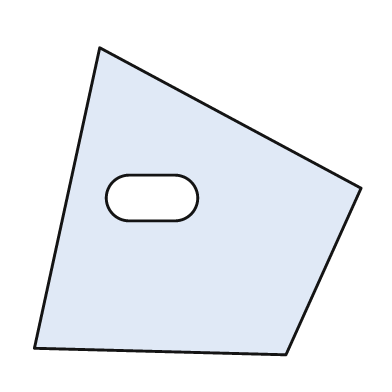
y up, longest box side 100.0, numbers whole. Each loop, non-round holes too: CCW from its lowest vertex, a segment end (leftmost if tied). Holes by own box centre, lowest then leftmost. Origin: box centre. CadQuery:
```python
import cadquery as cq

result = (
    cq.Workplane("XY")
    .moveTo(27.0, -47.0)
    .lineTo(50.0, 4.0)
    .lineTo(-30.0, 47.0)
    .lineTo(-50.0, -45.0)
    .close()
    .moveTo(-21.0, -6.0)
    .lineTo(-7.0, -6.0)
    .threePointArc((0.0, 1.0), (-7.0, 8.0))
    .lineTo(-21.0, 8.0)
    .threePointArc((-28.0, 1.0), (-21.0, -6.0))
    .close()
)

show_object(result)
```